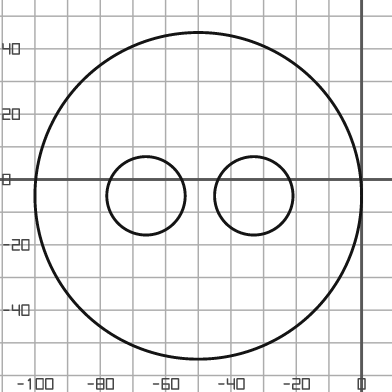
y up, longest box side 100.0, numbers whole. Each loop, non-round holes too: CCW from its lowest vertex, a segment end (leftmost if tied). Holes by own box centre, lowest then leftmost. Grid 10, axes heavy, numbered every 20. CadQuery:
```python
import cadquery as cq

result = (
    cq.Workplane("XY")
    .moveTo(-50.0, -5.0)
    .circle(50.0)
    .moveTo(-66.0, -5.0)
    .circle(12.0)
    .moveTo(-33.0, -5.0)
    .circle(12.0)
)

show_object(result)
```